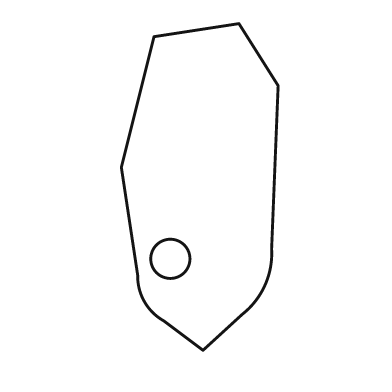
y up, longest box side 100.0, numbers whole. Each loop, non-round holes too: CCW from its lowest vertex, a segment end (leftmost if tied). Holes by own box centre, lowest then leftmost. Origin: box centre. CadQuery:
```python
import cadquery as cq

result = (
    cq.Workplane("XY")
    .moveTo(1.0, -50.0)
    .lineTo(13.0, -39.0)
    .threePointArc((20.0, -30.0), (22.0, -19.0))
    .lineTo(24.0, 31.0)
    .lineTo(12.0, 50.0)
    .lineTo(-14.0, 46.0)
    .lineTo(-24.0, 6.0)
    .lineTo(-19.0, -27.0)
    .threePointArc((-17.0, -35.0), (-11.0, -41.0))
    .close()
    .moveTo(-9.0, -22.0)
    .circle(6.0)
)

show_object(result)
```